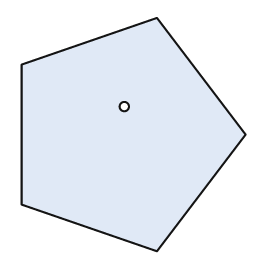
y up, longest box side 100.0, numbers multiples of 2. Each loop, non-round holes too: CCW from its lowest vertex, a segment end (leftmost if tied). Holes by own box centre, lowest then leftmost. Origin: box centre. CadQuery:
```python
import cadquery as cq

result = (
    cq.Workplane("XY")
    .moveTo(10.0, -50.0)
    .lineTo(48.0, 0.0)
    .lineTo(10.0, 50.0)
    .lineTo(-48.0, 30.0)
    .lineTo(-48.0, -30.0)
    .close()
    .moveTo(-4.0, 12.0)
    .circle(2.0)
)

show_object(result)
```